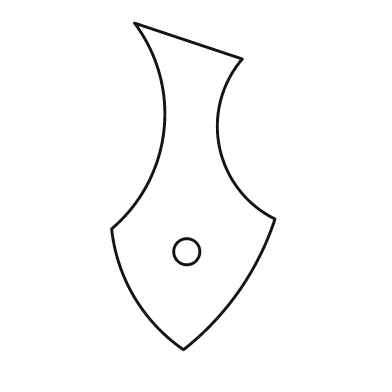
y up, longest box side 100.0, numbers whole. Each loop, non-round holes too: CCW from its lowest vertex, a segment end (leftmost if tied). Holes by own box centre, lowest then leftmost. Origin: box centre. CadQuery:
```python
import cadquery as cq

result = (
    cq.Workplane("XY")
    .moveTo(-3.0, -50.0)
    .threePointArc((14.0, -32.0), (25.0, -10.0))
    .threePointArc((8.0, 12.0), (15.0, 39.0))
    .lineTo(-18.0, 50.0)
    .threePointArc((-9.0, 17.0), (-25.0, -13.0))
    .threePointArc((-18.0, -34.0), (-3.0, -50.0))
    .close()
    .moveTo(-2.0, -20.0)
    .circle(4.0)
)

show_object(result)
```